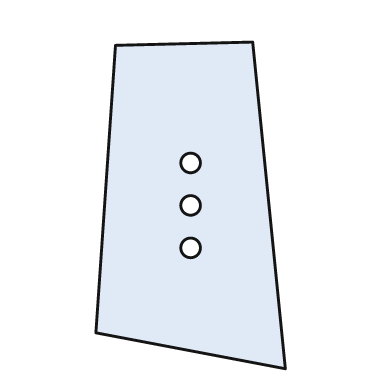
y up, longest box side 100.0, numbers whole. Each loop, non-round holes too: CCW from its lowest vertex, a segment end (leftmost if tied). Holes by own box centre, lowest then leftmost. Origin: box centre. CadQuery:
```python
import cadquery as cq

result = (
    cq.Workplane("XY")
    .moveTo(29.0, -50.0)
    .lineTo(19.0, 50.0)
    .lineTo(-23.0, 49.0)
    .lineTo(-29.0, -39.0)
    .close()
    .moveTo(0.0, -13.0)
    .circle(3.0)
    .moveTo(0.0, 0.0)
    .circle(3.0)
    .moveTo(0.0, 13.0)
    .circle(3.0)
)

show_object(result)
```